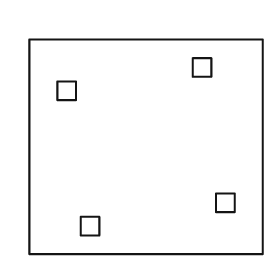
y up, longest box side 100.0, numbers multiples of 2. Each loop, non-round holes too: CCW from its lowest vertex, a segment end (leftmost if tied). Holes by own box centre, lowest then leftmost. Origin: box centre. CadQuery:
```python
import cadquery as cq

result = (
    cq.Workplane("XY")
    .moveTo(-50.0, -46.0)
    .lineTo(50.0, -46.0)
    .lineTo(50.0, 46.0)
    .lineTo(-50.0, 46.0)
    .close()
    .moveTo(-28.0, -38.0)
    .lineTo(-20.0, -38.0)
    .lineTo(-20.0, -30.0)
    .lineTo(-28.0, -30.0)
    .close()
    .moveTo(30.0, -28.0)
    .lineTo(38.0, -28.0)
    .lineTo(38.0, -20.0)
    .lineTo(30.0, -20.0)
    .close()
    .moveTo(-38.0, 20.0)
    .lineTo(-30.0, 20.0)
    .lineTo(-30.0, 28.0)
    .lineTo(-38.0, 28.0)
    .close()
    .moveTo(20.0, 30.0)
    .lineTo(28.0, 30.0)
    .lineTo(28.0, 38.0)
    .lineTo(20.0, 38.0)
    .close()
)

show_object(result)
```